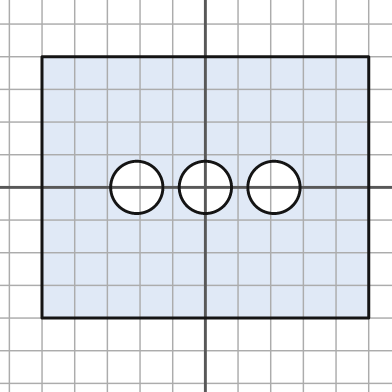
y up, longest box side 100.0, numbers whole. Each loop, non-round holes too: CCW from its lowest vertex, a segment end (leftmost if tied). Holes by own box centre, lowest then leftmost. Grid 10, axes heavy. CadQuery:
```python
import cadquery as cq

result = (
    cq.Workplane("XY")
    .moveTo(-50.0, -40.0)
    .lineTo(50.0, -40.0)
    .lineTo(50.0, 40.0)
    .lineTo(-50.0, 40.0)
    .close()
    .moveTo(-21.0, 0.0)
    .circle(8.0)
    .moveTo(0.0, 0.0)
    .circle(8.0)
    .moveTo(21.0, 0.0)
    .circle(8.0)
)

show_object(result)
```